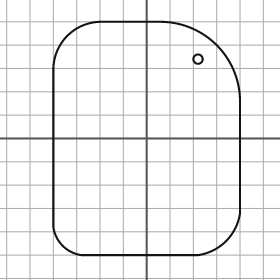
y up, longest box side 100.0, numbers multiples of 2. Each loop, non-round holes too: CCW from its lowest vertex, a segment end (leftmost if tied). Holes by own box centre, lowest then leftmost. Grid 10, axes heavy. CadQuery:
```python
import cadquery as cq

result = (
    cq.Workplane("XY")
    .moveTo(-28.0, -50.0)
    .lineTo(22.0, -50.0)
    .threePointArc((34.0, -44.0), (40.0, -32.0))
    .lineTo(40.0, 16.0)
    .threePointArc((30.0, 40.0), (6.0, 50.0))
    .lineTo(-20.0, 50.0)
    .threePointArc((-34.0, 44.0), (-40.0, 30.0))
    .lineTo(-40.0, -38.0)
    .threePointArc((-36.0, -46.0), (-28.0, -50.0))
    .close()
    .moveTo(22.0, 34.0)
    .circle(2.0)
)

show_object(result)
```